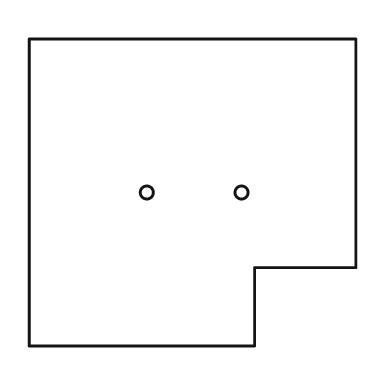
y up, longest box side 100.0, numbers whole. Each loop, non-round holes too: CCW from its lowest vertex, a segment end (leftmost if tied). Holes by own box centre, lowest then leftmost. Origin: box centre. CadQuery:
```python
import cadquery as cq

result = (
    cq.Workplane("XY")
    .moveTo(-50.0, -47.0)
    .lineTo(19.0, -47.0)
    .lineTo(19.0, -23.0)
    .lineTo(50.0, -23.0)
    .lineTo(50.0, 47.0)
    .lineTo(-50.0, 47.0)
    .close()
    .moveTo(-14.0, 0.0)
    .circle(2.0)
    .moveTo(15.0, 0.0)
    .circle(2.0)
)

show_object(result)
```